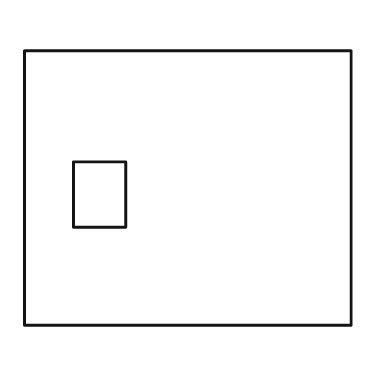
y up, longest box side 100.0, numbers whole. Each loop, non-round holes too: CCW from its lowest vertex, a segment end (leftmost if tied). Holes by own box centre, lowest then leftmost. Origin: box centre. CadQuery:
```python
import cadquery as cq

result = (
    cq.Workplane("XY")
    .moveTo(-50.0, -42.0)
    .lineTo(50.0, -42.0)
    .lineTo(50.0, 42.0)
    .lineTo(-50.0, 42.0)
    .close()
    .moveTo(-35.0, -12.0)
    .lineTo(-19.0, -12.0)
    .lineTo(-19.0, 8.0)
    .lineTo(-35.0, 8.0)
    .close()
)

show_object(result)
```